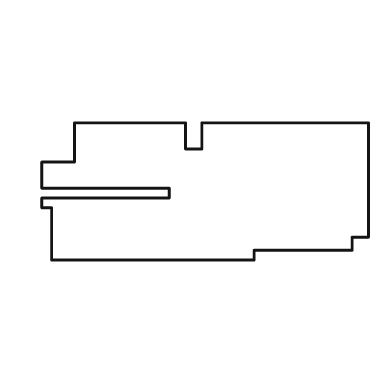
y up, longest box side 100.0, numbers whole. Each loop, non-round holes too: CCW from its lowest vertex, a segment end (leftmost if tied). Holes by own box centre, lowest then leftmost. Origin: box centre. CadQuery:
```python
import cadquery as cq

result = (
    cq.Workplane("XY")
    .moveTo(-47.0, -21.0)
    .lineTo(15.0, -21.0)
    .lineTo(15.0, -18.0)
    .lineTo(45.0, -18.0)
    .lineTo(45.0, -14.0)
    .lineTo(50.0, -14.0)
    .lineTo(50.0, 21.0)
    .lineTo(-1.0, 21.0)
    .lineTo(-1.0, 13.0)
    .lineTo(-6.0, 13.0)
    .lineTo(-6.0, 21.0)
    .lineTo(-40.0, 21.0)
    .lineTo(-40.0, 9.0)
    .lineTo(-50.0, 9.0)
    .lineTo(-50.0, 1.0)
    .lineTo(-11.0, 1.0)
    .lineTo(-11.0, -2.0)
    .lineTo(-50.0, -2.0)
    .lineTo(-50.0, -5.0)
    .lineTo(-47.0, -5.0)
    .close()
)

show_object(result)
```